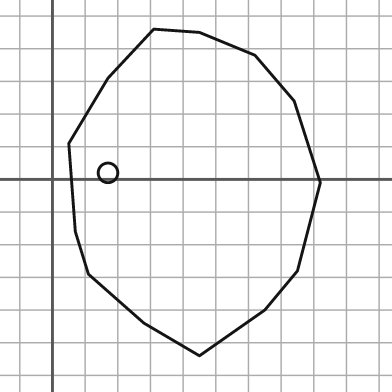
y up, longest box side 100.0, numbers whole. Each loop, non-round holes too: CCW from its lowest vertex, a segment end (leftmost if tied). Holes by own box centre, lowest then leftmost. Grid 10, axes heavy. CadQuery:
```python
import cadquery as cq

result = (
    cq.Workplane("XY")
    .moveTo(45.0, -54.0)
    .lineTo(65.0, -40.0)
    .lineTo(75.0, -28.0)
    .lineTo(82.0, -1.0)
    .lineTo(74.0, 24.0)
    .lineTo(62.0, 38.0)
    .lineTo(45.0, 45.0)
    .lineTo(31.0, 46.0)
    .lineTo(17.0, 31.0)
    .lineTo(5.0, 11.0)
    .lineTo(7.0, -16.0)
    .lineTo(11.0, -29.0)
    .lineTo(28.0, -44.0)
    .close()
    .moveTo(17.0, 2.0)
    .circle(3.0)
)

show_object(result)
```